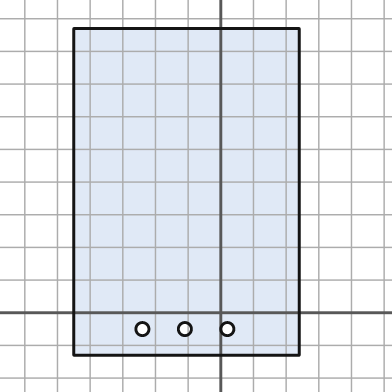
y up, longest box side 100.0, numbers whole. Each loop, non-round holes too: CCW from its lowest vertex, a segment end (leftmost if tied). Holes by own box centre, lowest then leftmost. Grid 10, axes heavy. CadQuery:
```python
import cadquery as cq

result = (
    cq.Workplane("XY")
    .moveTo(-45.0, -13.0)
    .lineTo(24.0, -13.0)
    .lineTo(24.0, 87.0)
    .lineTo(-45.0, 87.0)
    .close()
    .moveTo(-24.0, -5.0)
    .circle(2.0)
    .moveTo(-11.0, -5.0)
    .circle(2.0)
    .moveTo(2.0, -5.0)
    .circle(2.0)
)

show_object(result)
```